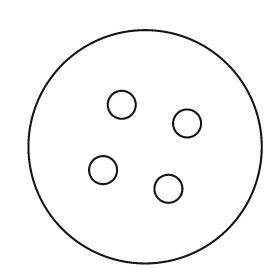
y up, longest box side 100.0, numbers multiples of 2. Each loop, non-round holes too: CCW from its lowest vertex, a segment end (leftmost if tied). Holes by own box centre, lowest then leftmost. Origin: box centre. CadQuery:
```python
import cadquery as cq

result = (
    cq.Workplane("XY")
    .moveTo(0.0, 0.0)
    .circle(50.0)
    .moveTo(10.0, -18.0)
    .circle(6.0)
    .moveTo(-18.0, -10.0)
    .circle(6.0)
    .moveTo(18.0, 10.0)
    .circle(6.0)
    .moveTo(-10.0, 18.0)
    .circle(6.0)
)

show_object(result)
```